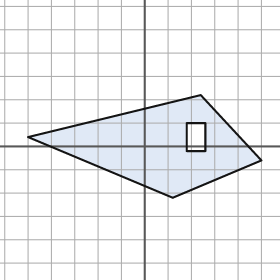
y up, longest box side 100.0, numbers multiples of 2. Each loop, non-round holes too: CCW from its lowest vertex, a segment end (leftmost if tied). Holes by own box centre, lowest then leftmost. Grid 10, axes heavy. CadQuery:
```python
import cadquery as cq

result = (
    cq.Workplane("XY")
    .moveTo(12.0, -22.0)
    .lineTo(50.0, -6.0)
    .lineTo(24.0, 22.0)
    .lineTo(-50.0, 4.0)
    .close()
    .moveTo(18.0, -2.0)
    .lineTo(26.0, -2.0)
    .lineTo(26.0, 10.0)
    .lineTo(18.0, 10.0)
    .close()
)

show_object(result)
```